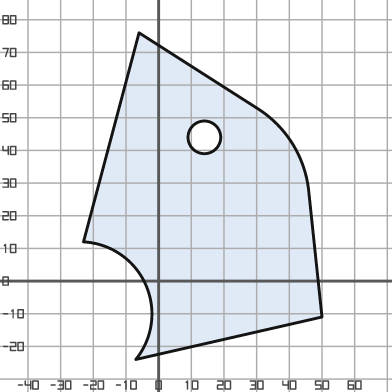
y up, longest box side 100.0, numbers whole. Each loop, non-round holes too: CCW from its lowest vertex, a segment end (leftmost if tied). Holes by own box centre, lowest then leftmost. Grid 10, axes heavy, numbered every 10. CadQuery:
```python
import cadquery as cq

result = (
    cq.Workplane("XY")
    .moveTo(-7.0, -24.0)
    .lineTo(50.0, -11.0)
    .lineTo(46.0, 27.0)
    .threePointArc((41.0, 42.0), (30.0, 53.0))
    .lineTo(-6.0, 76.0)
    .lineTo(-23.0, 12.0)
    .threePointArc((-4.0, -1.0), (-7.0, -24.0))
    .close()
    .moveTo(14.0, 44.0)
    .circle(5.0)
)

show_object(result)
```